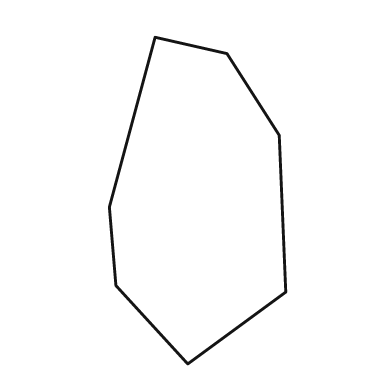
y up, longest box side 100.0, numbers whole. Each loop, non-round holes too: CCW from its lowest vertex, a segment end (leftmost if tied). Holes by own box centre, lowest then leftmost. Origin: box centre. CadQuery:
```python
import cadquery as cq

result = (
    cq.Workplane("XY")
    .moveTo(-3.0, -50.0)
    .lineTo(27.0, -28.0)
    .lineTo(25.0, 20.0)
    .lineTo(9.0, 45.0)
    .lineTo(-13.0, 50.0)
    .lineTo(-27.0, -2.0)
    .lineTo(-25.0, -26.0)
    .close()
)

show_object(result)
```